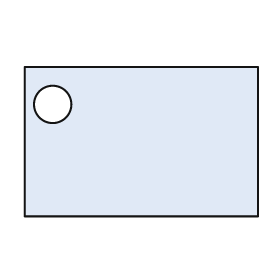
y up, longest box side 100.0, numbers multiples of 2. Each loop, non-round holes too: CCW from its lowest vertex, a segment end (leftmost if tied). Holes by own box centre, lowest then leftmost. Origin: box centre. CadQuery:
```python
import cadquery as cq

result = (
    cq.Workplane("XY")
    .moveTo(-50.0, -32.0)
    .lineTo(50.0, -32.0)
    .lineTo(50.0, 32.0)
    .lineTo(-50.0, 32.0)
    .close()
    .moveTo(-38.0, 16.0)
    .circle(8.0)
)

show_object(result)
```